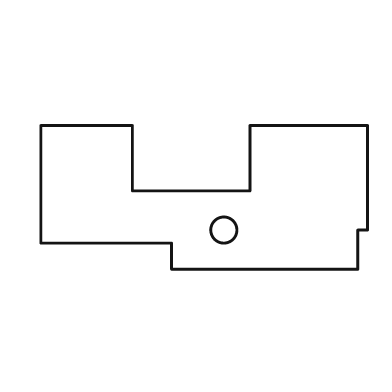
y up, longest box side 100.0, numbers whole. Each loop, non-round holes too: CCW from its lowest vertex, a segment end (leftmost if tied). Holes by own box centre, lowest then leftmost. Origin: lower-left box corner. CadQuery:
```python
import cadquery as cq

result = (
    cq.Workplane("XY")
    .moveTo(40.0, 0.0)
    .lineTo(97.0, 0.0)
    .lineTo(97.0, 12.0)
    .lineTo(100.0, 12.0)
    .lineTo(100.0, 44.0)
    .lineTo(64.0, 44.0)
    .lineTo(64.0, 24.0)
    .lineTo(28.0, 24.0)
    .lineTo(28.0, 44.0)
    .lineTo(0.0, 44.0)
    .lineTo(0.0, 8.0)
    .lineTo(40.0, 8.0)
    .close()
    .moveTo(56.0, 12.0)
    .circle(4.0)
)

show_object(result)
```